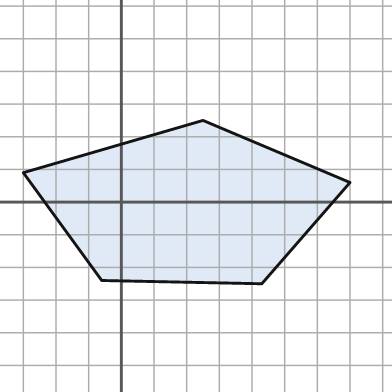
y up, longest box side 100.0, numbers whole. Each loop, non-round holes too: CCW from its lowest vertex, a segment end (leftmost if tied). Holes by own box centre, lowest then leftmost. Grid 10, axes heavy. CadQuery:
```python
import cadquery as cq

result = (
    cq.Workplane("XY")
    .moveTo(43.0, -25.0)
    .lineTo(70.0, 6.0)
    .lineTo(25.0, 25.0)
    .lineTo(-30.0, 9.0)
    .lineTo(-6.0, -24.0)
    .close()
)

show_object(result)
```